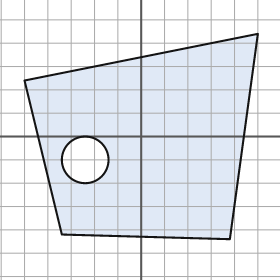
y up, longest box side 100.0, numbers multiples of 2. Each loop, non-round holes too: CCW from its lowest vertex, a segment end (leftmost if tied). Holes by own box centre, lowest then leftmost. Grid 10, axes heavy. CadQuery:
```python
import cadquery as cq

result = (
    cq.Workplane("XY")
    .moveTo(38.0, -44.0)
    .lineTo(50.0, 44.0)
    .lineTo(-50.0, 24.0)
    .lineTo(-34.0, -42.0)
    .close()
    .moveTo(-24.0, -10.0)
    .circle(10.0)
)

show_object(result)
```